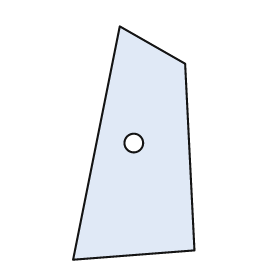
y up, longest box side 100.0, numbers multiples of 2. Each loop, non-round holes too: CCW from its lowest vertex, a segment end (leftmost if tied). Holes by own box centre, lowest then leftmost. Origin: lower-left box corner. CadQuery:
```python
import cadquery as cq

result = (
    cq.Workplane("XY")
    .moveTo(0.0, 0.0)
    .lineTo(52.0, 4.0)
    .lineTo(48.0, 84.0)
    .lineTo(20.0, 100.0)
    .close()
    .moveTo(26.0, 50.0)
    .circle(4.0)
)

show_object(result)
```